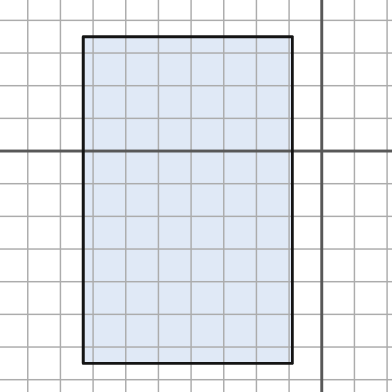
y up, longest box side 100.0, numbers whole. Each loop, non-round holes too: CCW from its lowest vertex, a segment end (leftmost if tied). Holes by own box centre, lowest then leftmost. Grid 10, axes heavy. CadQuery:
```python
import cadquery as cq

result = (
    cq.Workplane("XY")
    .moveTo(-73.0, -65.0)
    .lineTo(-9.0, -65.0)
    .lineTo(-9.0, 35.0)
    .lineTo(-73.0, 35.0)
    .close()
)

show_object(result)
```